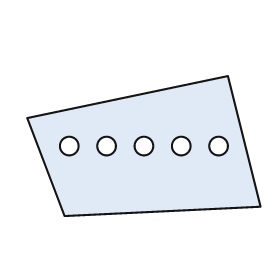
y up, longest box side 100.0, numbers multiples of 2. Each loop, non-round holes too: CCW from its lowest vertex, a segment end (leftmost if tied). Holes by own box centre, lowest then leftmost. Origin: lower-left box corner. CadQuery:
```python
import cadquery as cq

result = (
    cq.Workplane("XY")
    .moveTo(16.0, 0.0)
    .lineTo(100.0, 4.0)
    .lineTo(86.0, 60.0)
    .lineTo(0.0, 42.0)
    .close()
    .moveTo(18.0, 30.0)
    .circle(4.0)
    .moveTo(34.0, 30.0)
    .circle(4.0)
    .moveTo(50.0, 30.0)
    .circle(4.0)
    .moveTo(66.0, 30.0)
    .circle(4.0)
    .moveTo(82.0, 30.0)
    .circle(4.0)
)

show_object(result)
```